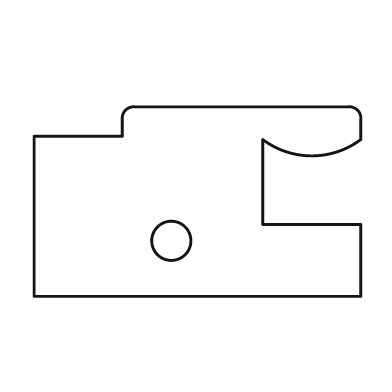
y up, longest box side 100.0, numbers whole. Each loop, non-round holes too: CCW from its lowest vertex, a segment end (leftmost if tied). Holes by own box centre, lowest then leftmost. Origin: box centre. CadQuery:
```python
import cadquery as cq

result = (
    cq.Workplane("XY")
    .moveTo(-50.0, -29.0)
    .lineTo(50.0, -29.0)
    .lineTo(50.0, -7.0)
    .lineTo(20.0, -7.0)
    .lineTo(20.0, 19.0)
    .threePointArc((35.0, 14.0), (50.0, 19.0))
    .lineTo(50.0, 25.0)
    .threePointArc((49.0, 28.0), (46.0, 29.0))
    .lineTo(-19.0, 29.0)
    .threePointArc((-22.0, 28.0), (-23.0, 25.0))
    .lineTo(-23.0, 20.0)
    .lineTo(-50.0, 20.0)
    .close()
    .moveTo(-8.0, -12.0)
    .circle(6.0)
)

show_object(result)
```